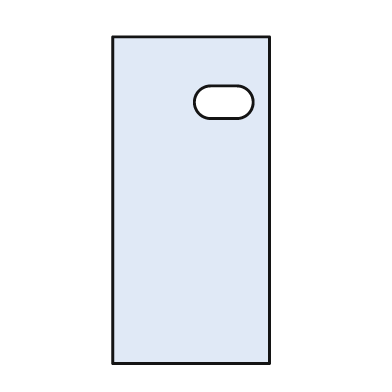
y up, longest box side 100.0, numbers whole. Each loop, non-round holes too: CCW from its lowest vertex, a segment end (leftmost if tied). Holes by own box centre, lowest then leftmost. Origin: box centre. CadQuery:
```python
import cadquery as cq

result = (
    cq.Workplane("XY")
    .moveTo(-24.0, -50.0)
    .lineTo(24.0, -50.0)
    .lineTo(24.0, 50.0)
    .lineTo(-24.0, 50.0)
    .close()
    .moveTo(6.0, 25.0)
    .lineTo(14.0, 25.0)
    .threePointArc((19.0, 30.0), (14.0, 35.0))
    .lineTo(6.0, 35.0)
    .threePointArc((1.0, 30.0), (6.0, 25.0))
    .close()
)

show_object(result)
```